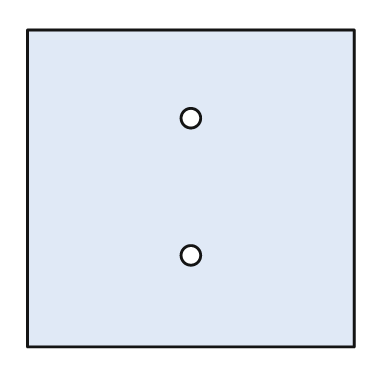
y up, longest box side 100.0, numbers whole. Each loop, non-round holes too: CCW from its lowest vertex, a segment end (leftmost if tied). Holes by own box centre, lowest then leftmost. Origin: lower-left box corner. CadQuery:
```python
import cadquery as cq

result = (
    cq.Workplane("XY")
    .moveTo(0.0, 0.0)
    .lineTo(100.0, 0.0)
    .lineTo(100.0, 97.0)
    .lineTo(0.0, 97.0)
    .close()
    .moveTo(50.0, 28.0)
    .circle(3.0)
    .moveTo(50.0, 70.0)
    .circle(3.0)
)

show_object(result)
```